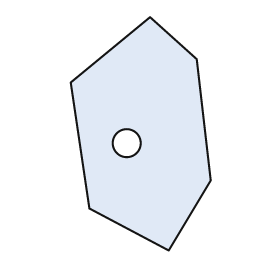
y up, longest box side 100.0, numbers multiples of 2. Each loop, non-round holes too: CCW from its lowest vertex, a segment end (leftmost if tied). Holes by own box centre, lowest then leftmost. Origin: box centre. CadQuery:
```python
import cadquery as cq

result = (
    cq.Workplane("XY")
    .moveTo(12.0, -50.0)
    .lineTo(30.0, -20.0)
    .lineTo(24.0, 32.0)
    .lineTo(4.0, 50.0)
    .lineTo(-30.0, 22.0)
    .lineTo(-22.0, -32.0)
    .close()
    .moveTo(-6.0, -4.0)
    .circle(6.0)
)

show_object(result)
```